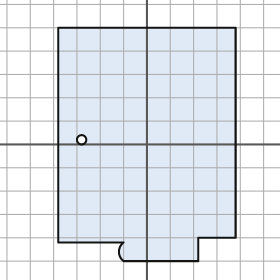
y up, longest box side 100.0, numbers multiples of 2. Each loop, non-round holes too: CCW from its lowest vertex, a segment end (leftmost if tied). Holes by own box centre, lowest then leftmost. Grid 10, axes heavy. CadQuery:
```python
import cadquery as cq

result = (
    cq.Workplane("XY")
    .moveTo(-10.0, -50.0)
    .lineTo(22.0, -50.0)
    .lineTo(22.0, -40.0)
    .lineTo(38.0, -40.0)
    .lineTo(38.0, 50.0)
    .lineTo(-38.0, 50.0)
    .lineTo(-38.0, -42.0)
    .lineTo(-10.0, -42.0)
    .threePointArc((-12.0, -46.0), (-10.0, -50.0))
    .close()
    .moveTo(-28.0, 2.0)
    .circle(2.0)
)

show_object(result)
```